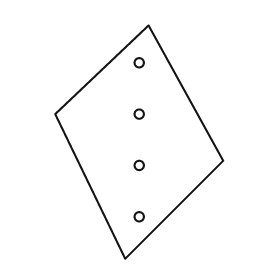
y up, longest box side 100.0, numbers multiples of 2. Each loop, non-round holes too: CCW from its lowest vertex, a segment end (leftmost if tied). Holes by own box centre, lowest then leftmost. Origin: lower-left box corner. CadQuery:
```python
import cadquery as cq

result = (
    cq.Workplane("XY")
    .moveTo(30.0, 0.0)
    .lineTo(72.0, 42.0)
    .lineTo(40.0, 100.0)
    .lineTo(0.0, 62.0)
    .close()
    .moveTo(36.0, 18.0)
    .circle(2.0)
    .moveTo(36.0, 40.0)
    .circle(2.0)
    .moveTo(36.0, 62.0)
    .circle(2.0)
    .moveTo(36.0, 84.0)
    .circle(2.0)
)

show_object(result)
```